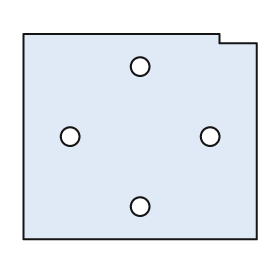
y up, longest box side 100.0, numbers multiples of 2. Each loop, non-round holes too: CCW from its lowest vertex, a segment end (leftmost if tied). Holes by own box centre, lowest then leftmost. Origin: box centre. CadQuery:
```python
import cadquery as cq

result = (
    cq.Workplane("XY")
    .moveTo(-50.0, -44.0)
    .lineTo(50.0, -44.0)
    .lineTo(50.0, 40.0)
    .lineTo(34.0, 40.0)
    .lineTo(34.0, 44.0)
    .lineTo(-50.0, 44.0)
    .close()
    .moveTo(0.0, -30.0)
    .circle(4.0)
    .moveTo(-30.0, 0.0)
    .circle(4.0)
    .moveTo(30.0, 0.0)
    .circle(4.0)
    .moveTo(0.0, 30.0)
    .circle(4.0)
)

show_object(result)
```